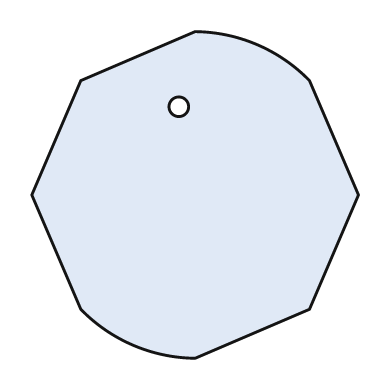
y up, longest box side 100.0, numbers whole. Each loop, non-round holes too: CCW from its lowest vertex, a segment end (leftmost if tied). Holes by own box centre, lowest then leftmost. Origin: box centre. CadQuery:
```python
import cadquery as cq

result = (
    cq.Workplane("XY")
    .moveTo(0.0, -50.0)
    .lineTo(35.0, -35.0)
    .lineTo(50.0, 0.0)
    .lineTo(35.0, 35.0)
    .threePointArc((19.0, 46.0), (0.0, 50.0))
    .lineTo(-35.0, 35.0)
    .lineTo(-50.0, 0.0)
    .lineTo(-35.0, -35.0)
    .threePointArc((-19.0, -46.0), (0.0, -50.0))
    .close()
    .moveTo(-5.0, 27.0)
    .circle(3.0)
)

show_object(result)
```